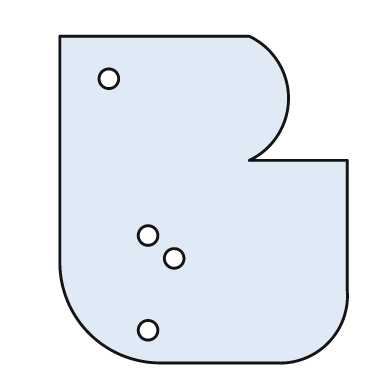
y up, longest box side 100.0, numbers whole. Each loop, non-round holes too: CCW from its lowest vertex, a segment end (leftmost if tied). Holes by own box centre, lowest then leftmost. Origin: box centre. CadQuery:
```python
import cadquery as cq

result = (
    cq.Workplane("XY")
    .moveTo(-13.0, -50.0)
    .lineTo(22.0, -50.0)
    .threePointArc((38.0, -44.0), (44.0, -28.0))
    .lineTo(44.0, 12.0)
    .lineTo(14.0, 12.0)
    .threePointArc((26.0, 31.0), (14.0, 50.0))
    .lineTo(-44.0, 50.0)
    .lineTo(-44.0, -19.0)
    .threePointArc((-35.0, -41.0), (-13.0, -50.0))
    .close()
    .moveTo(-17.0, -40.0)
    .circle(3.0)
    .moveTo(-9.0, -18.0)
    .circle(3.0)
    .moveTo(-17.0, -11.0)
    .circle(3.0)
    .moveTo(-29.0, 37.0)
    .circle(3.0)
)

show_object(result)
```